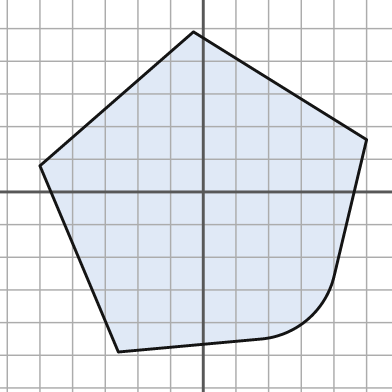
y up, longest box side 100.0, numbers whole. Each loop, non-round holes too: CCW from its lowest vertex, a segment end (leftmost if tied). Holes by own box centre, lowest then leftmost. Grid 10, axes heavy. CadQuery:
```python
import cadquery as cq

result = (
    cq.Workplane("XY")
    .moveTo(-26.0, -49.0)
    .lineTo(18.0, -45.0)
    .threePointArc((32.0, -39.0), (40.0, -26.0))
    .lineTo(50.0, 16.0)
    .lineTo(-3.0, 49.0)
    .lineTo(-50.0, 8.0)
    .close()
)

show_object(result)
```